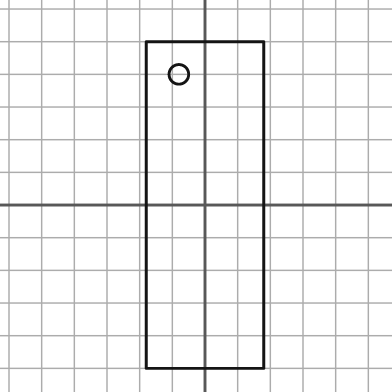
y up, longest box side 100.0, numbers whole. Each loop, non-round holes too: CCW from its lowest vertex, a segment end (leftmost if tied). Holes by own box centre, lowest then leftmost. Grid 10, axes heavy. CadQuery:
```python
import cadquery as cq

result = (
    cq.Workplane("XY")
    .moveTo(-18.0, -50.0)
    .lineTo(18.0, -50.0)
    .lineTo(18.0, 50.0)
    .lineTo(-18.0, 50.0)
    .close()
    .moveTo(-8.0, 40.0)
    .circle(3.0)
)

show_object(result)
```